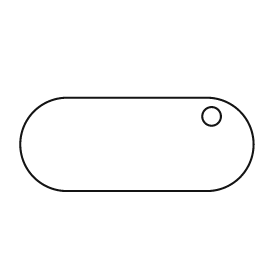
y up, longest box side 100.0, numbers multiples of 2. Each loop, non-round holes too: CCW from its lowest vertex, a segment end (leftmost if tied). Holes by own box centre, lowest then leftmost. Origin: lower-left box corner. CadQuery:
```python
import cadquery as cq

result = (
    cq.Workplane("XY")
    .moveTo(20.0, 0.0)
    .lineTo(80.0, 0.0)
    .threePointArc((100.0, 20.0), (80.0, 40.0))
    .lineTo(20.0, 40.0)
    .threePointArc((0.0, 20.0), (20.0, 0.0))
    .close()
    .moveTo(82.0, 32.0)
    .circle(4.0)
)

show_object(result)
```